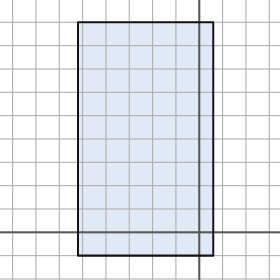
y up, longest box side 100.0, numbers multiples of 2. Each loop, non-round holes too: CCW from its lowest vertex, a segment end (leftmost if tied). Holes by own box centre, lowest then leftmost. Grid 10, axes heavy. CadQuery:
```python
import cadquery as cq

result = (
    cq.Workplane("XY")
    .moveTo(-52.0, -10.0)
    .lineTo(6.0, -10.0)
    .lineTo(6.0, 90.0)
    .lineTo(-52.0, 90.0)
    .close()
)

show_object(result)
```